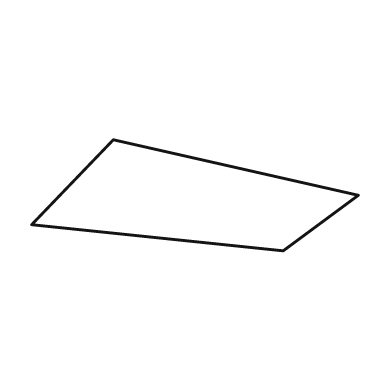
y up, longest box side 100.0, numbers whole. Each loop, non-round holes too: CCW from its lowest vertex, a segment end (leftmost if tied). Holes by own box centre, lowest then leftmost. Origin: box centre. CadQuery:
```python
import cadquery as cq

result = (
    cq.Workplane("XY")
    .moveTo(27.0, -17.0)
    .lineTo(50.0, 0.0)
    .lineTo(-25.0, 17.0)
    .lineTo(-50.0, -9.0)
    .close()
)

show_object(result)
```